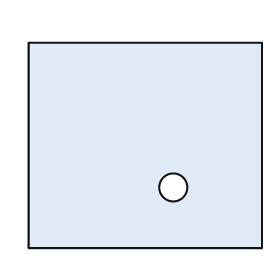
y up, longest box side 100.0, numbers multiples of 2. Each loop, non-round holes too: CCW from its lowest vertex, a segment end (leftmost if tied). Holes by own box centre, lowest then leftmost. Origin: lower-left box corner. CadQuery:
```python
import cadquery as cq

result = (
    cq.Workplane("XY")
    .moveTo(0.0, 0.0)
    .lineTo(100.0, 0.0)
    .lineTo(100.0, 88.0)
    .lineTo(0.0, 88.0)
    .close()
    .moveTo(62.0, 26.0)
    .circle(6.0)
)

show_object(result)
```